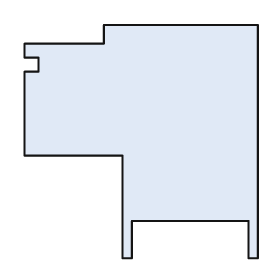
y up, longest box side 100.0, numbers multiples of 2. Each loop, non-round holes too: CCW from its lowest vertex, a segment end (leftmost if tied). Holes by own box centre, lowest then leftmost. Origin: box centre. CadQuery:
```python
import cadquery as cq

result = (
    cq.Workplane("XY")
    .moveTo(-8.0, -50.0)
    .lineTo(-4.0, -50.0)
    .lineTo(-4.0, -34.0)
    .lineTo(46.0, -34.0)
    .lineTo(46.0, -50.0)
    .lineTo(50.0, -50.0)
    .lineTo(50.0, 50.0)
    .lineTo(-16.0, 50.0)
    .lineTo(-16.0, 42.0)
    .lineTo(-50.0, 42.0)
    .lineTo(-50.0, 36.0)
    .lineTo(-44.0, 36.0)
    .lineTo(-44.0, 30.0)
    .lineTo(-50.0, 30.0)
    .lineTo(-50.0, -6.0)
    .lineTo(-8.0, -6.0)
    .close()
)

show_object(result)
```